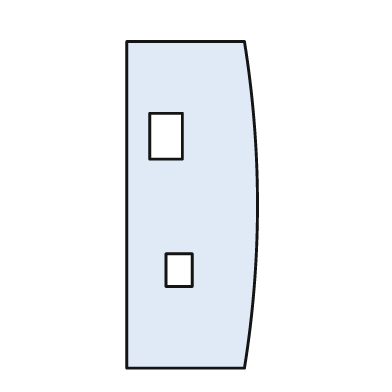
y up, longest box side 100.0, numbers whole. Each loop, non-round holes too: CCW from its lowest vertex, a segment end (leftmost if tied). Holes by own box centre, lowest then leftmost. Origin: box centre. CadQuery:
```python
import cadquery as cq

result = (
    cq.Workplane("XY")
    .moveTo(-20.0, -50.0)
    .lineTo(16.0, -50.0)
    .threePointArc((20.0, 0.0), (16.0, 50.0))
    .lineTo(-20.0, 50.0)
    .close()
    .moveTo(-8.0, -25.0)
    .lineTo(0.0, -25.0)
    .lineTo(0.0, -15.0)
    .lineTo(-8.0, -15.0)
    .close()
    .moveTo(-13.0, 14.0)
    .lineTo(-3.0, 14.0)
    .lineTo(-3.0, 28.0)
    .lineTo(-13.0, 28.0)
    .close()
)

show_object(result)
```